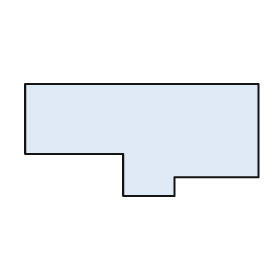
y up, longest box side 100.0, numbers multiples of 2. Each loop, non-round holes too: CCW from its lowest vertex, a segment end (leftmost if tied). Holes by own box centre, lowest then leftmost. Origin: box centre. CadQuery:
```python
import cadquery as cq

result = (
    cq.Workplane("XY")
    .moveTo(-8.0, -24.0)
    .lineTo(14.0, -24.0)
    .lineTo(14.0, -16.0)
    .lineTo(50.0, -16.0)
    .lineTo(50.0, 24.0)
    .lineTo(-50.0, 24.0)
    .lineTo(-50.0, -6.0)
    .lineTo(-8.0, -6.0)
    .close()
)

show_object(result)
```